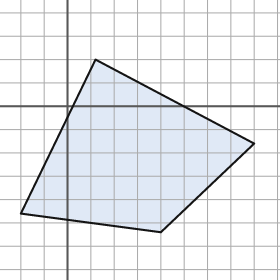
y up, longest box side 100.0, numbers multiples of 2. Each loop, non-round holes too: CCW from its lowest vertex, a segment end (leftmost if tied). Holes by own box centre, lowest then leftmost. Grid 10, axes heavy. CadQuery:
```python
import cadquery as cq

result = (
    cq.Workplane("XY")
    .moveTo(40.0, -54.0)
    .lineTo(80.0, -16.0)
    .lineTo(12.0, 20.0)
    .lineTo(-20.0, -46.0)
    .close()
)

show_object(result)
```